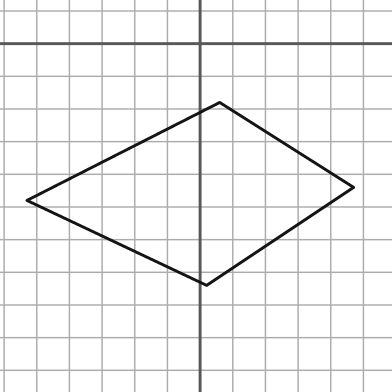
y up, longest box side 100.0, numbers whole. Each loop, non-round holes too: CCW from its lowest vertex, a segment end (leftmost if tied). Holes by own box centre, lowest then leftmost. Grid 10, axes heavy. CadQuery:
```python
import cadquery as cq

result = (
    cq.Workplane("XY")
    .moveTo(2.0, -74.0)
    .lineTo(47.0, -44.0)
    .lineTo(6.0, -18.0)
    .lineTo(-53.0, -48.0)
    .close()
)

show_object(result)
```